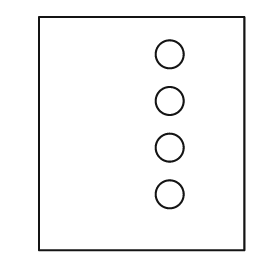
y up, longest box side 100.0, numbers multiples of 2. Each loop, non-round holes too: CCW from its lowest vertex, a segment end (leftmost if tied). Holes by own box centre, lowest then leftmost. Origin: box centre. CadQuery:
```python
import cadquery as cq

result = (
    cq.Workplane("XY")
    .moveTo(-44.0, -50.0)
    .lineTo(44.0, -50.0)
    .lineTo(44.0, 50.0)
    .lineTo(-44.0, 50.0)
    .close()
    .moveTo(12.0, -26.0)
    .circle(6.0)
    .moveTo(12.0, -6.0)
    .circle(6.0)
    .moveTo(12.0, 14.0)
    .circle(6.0)
    .moveTo(12.0, 34.0)
    .circle(6.0)
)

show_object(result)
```